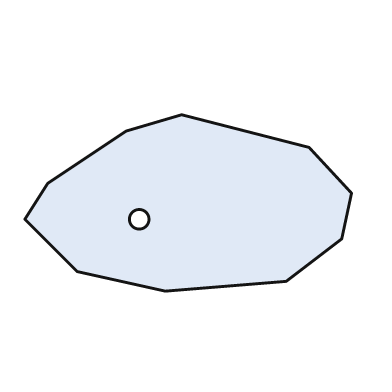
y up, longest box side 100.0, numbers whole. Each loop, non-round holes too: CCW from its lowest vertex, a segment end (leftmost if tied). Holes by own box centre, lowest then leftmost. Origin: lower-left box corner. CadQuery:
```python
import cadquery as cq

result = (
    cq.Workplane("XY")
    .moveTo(43.0, 0.0)
    .lineTo(80.0, 3.0)
    .lineTo(97.0, 16.0)
    .lineTo(100.0, 30.0)
    .lineTo(87.0, 44.0)
    .lineTo(48.0, 54.0)
    .lineTo(31.0, 49.0)
    .lineTo(7.0, 33.0)
    .lineTo(0.0, 22.0)
    .lineTo(16.0, 6.0)
    .close()
    .moveTo(35.0, 22.0)
    .circle(3.0)
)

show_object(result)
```